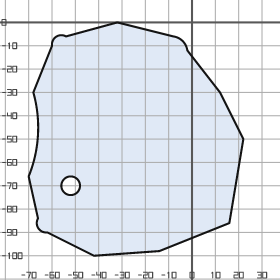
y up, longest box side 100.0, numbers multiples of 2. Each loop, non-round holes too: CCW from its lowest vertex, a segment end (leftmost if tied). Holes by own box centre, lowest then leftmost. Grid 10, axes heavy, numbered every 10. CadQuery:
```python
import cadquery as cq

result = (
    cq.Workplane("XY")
    .moveTo(-42.0, -100.0)
    .lineTo(-14.0, -98.0)
    .lineTo(16.0, -86.0)
    .lineTo(22.0, -50.0)
    .lineTo(12.0, -30.0)
    .lineTo(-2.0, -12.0)
    .threePointArc((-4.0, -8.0), (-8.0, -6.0))
    .lineTo(-32.0, 0.0)
    .lineTo(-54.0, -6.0)
    .threePointArc((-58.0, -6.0), (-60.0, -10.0))
    .lineTo(-68.0, -30.0)
    .threePointArc((-66.0, -48.0), (-70.0, -66.0))
    .lineTo(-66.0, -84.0)
    .threePointArc((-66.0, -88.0), (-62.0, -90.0))
    .close()
    .moveTo(-52.0, -70.0)
    .circle(4.0)
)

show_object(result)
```